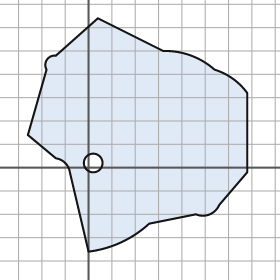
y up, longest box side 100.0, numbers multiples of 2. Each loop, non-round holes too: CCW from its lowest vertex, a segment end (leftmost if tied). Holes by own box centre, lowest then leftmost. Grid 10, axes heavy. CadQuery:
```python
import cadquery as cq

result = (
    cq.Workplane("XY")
    .moveTo(0.0, -36.0)
    .threePointArc((14.0, -32.0), (26.0, -24.0))
    .lineTo(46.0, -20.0)
    .threePointArc((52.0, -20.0), (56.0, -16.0))
    .lineTo(68.0, -2.0)
    .lineTo(68.0, 32.0)
    .threePointArc((62.0, 38.0), (54.0, 42.0))
    .threePointArc((44.0, 48.0), (32.0, 50.0))
    .lineTo(4.0, 64.0)
    .lineTo(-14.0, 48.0)
    .threePointArc((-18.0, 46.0), (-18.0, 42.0))
    .lineTo(-26.0, 14.0)
    .lineTo(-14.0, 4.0)
    .threePointArc((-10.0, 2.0), (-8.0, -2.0))
    .close()
    .moveTo(2.0, 2.0)
    .circle(4.0)
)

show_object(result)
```